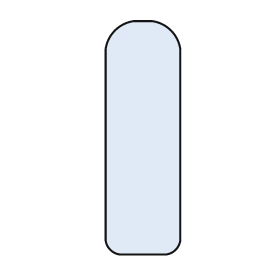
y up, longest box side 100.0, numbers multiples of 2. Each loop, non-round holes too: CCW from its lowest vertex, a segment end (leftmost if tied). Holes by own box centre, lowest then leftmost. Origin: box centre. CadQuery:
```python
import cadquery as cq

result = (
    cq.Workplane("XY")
    .moveTo(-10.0, -50.0)
    .lineTo(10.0, -50.0)
    .threePointArc((14.0, -48.0), (16.0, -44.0))
    .lineTo(16.0, 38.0)
    .threePointArc((12.0, 46.0), (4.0, 50.0))
    .lineTo(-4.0, 50.0)
    .threePointArc((-12.0, 46.0), (-16.0, 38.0))
    .lineTo(-16.0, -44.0)
    .threePointArc((-14.0, -48.0), (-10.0, -50.0))
    .close()
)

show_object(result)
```